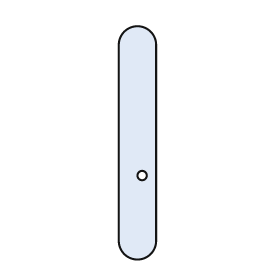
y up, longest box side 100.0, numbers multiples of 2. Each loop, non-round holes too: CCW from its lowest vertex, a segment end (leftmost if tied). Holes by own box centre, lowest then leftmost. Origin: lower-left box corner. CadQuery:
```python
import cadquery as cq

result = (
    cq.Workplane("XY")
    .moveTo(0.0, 8.0)
    .threePointArc((8.0, 0.0), (16.0, 8.0))
    .lineTo(16.0, 92.0)
    .threePointArc((8.0, 100.0), (0.0, 92.0))
    .close()
    .moveTo(10.0, 36.0)
    .circle(2.0)
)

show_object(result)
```